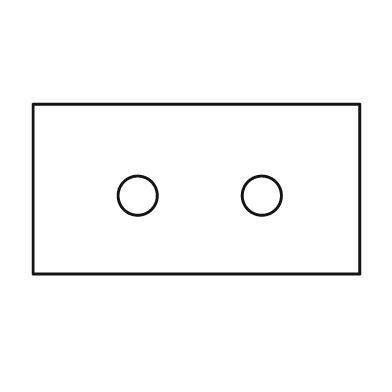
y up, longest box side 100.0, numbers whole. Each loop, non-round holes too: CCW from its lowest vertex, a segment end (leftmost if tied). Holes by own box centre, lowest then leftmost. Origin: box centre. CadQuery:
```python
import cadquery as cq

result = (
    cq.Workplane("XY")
    .moveTo(-50.0, -26.0)
    .lineTo(50.0, -26.0)
    .lineTo(50.0, 26.0)
    .lineTo(-50.0, 26.0)
    .close()
    .moveTo(-18.0, -2.0)
    .circle(6.0)
    .moveTo(20.0, -2.0)
    .circle(6.0)
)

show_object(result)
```